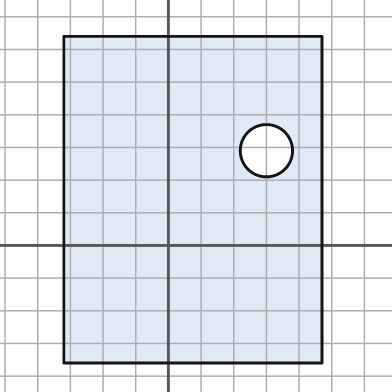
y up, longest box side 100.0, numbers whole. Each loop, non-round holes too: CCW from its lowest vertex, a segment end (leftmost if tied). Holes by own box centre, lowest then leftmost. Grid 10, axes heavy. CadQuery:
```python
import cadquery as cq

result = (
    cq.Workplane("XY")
    .moveTo(-32.0, -36.0)
    .lineTo(47.0, -36.0)
    .lineTo(47.0, 64.0)
    .lineTo(-32.0, 64.0)
    .close()
    .moveTo(30.0, 29.0)
    .circle(8.0)
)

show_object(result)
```